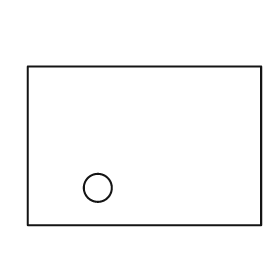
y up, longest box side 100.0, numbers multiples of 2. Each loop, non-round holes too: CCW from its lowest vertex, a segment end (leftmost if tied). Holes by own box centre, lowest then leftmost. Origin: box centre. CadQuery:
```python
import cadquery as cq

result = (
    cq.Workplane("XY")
    .moveTo(-50.0, -34.0)
    .lineTo(50.0, -34.0)
    .lineTo(50.0, 34.0)
    .lineTo(-50.0, 34.0)
    .close()
    .moveTo(-20.0, -18.0)
    .circle(6.0)
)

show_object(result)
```